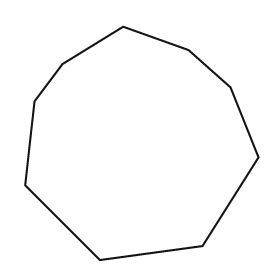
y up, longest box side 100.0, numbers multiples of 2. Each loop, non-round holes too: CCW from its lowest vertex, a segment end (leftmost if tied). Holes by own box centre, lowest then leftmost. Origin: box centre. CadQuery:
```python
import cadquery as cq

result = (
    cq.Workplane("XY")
    .moveTo(-18.0, -50.0)
    .lineTo(26.0, -44.0)
    .lineTo(50.0, -6.0)
    .lineTo(38.0, 24.0)
    .lineTo(20.0, 40.0)
    .lineTo(-8.0, 50.0)
    .lineTo(-34.0, 34.0)
    .lineTo(-46.0, 18.0)
    .lineTo(-50.0, -18.0)
    .close()
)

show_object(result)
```